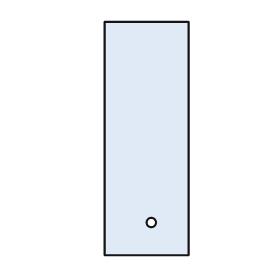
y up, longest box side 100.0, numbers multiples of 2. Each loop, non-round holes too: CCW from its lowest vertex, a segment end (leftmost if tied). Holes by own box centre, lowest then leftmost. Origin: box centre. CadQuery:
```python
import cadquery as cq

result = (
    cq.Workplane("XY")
    .moveTo(-18.0, -50.0)
    .lineTo(18.0, -50.0)
    .lineTo(18.0, 50.0)
    .lineTo(-18.0, 50.0)
    .close()
    .moveTo(2.0, -36.0)
    .circle(2.0)
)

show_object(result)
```